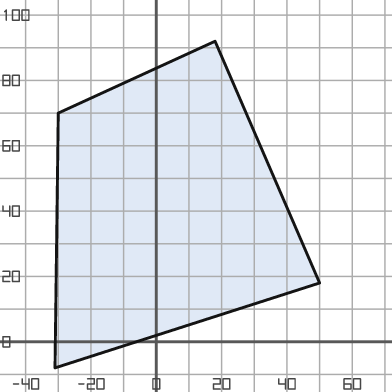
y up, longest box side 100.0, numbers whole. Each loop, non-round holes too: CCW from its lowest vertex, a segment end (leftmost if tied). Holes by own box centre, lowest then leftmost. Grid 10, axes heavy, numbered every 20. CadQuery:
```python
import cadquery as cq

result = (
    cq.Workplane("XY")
    .moveTo(-31.0, -8.0)
    .lineTo(50.0, 18.0)
    .lineTo(18.0, 92.0)
    .lineTo(-30.0, 70.0)
    .close()
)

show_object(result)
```